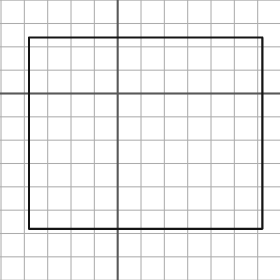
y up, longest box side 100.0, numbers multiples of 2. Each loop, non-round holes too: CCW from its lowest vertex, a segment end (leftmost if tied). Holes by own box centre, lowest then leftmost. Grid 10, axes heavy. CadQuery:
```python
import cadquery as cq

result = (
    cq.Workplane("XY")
    .moveTo(-38.0, -58.0)
    .lineTo(62.0, -58.0)
    .lineTo(62.0, 24.0)
    .lineTo(-38.0, 24.0)
    .close()
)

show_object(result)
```